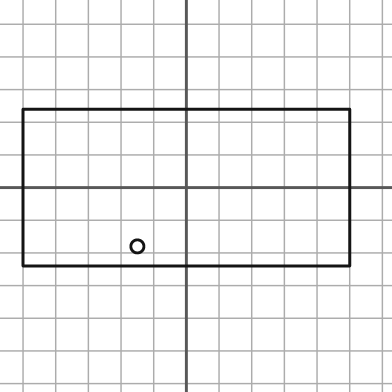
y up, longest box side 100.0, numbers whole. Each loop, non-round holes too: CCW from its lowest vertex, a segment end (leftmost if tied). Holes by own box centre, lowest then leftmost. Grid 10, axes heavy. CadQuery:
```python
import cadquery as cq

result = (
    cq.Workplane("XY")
    .moveTo(-50.0, -24.0)
    .lineTo(50.0, -24.0)
    .lineTo(50.0, 24.0)
    .lineTo(-50.0, 24.0)
    .close()
    .moveTo(-15.0, -18.0)
    .circle(2.0)
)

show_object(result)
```